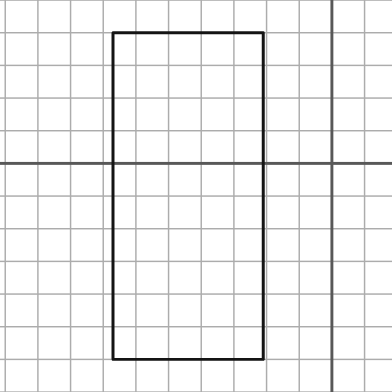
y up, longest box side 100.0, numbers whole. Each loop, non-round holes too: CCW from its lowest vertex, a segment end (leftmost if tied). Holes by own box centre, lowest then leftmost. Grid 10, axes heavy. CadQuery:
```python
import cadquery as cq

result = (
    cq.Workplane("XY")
    .moveTo(-67.0, -60.0)
    .lineTo(-21.0, -60.0)
    .lineTo(-21.0, 40.0)
    .lineTo(-67.0, 40.0)
    .close()
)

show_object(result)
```